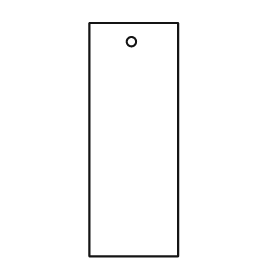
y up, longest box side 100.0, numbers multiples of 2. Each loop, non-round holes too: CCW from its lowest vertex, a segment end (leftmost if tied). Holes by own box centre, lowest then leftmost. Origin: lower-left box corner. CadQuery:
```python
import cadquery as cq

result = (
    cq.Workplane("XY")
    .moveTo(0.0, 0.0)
    .lineTo(38.0, 0.0)
    .lineTo(38.0, 100.0)
    .lineTo(0.0, 100.0)
    .close()
    .moveTo(18.0, 92.0)
    .circle(2.0)
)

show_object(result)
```